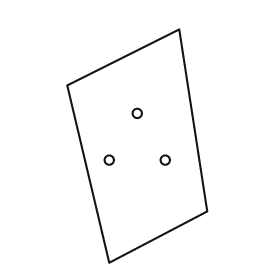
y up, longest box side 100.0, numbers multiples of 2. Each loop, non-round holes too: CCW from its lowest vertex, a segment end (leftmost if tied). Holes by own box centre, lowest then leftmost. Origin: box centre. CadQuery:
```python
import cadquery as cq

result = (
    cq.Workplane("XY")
    .moveTo(-12.0, -50.0)
    .lineTo(30.0, -28.0)
    .lineTo(18.0, 50.0)
    .lineTo(-30.0, 26.0)
    .close()
    .moveTo(-12.0, -6.0)
    .circle(2.0)
    .moveTo(12.0, -6.0)
    .circle(2.0)
    .moveTo(0.0, 14.0)
    .circle(2.0)
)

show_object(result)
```